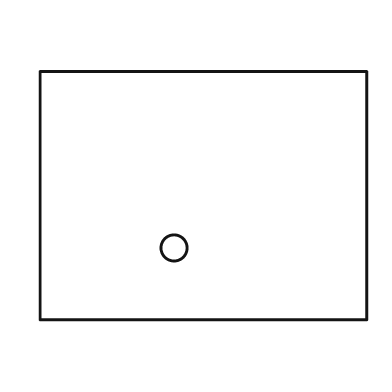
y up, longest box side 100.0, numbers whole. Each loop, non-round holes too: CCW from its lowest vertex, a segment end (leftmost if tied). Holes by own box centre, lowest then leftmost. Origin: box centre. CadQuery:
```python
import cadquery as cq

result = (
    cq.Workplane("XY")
    .moveTo(-50.0, -38.0)
    .lineTo(50.0, -38.0)
    .lineTo(50.0, 38.0)
    .lineTo(-50.0, 38.0)
    .close()
    .moveTo(-9.0, -16.0)
    .circle(4.0)
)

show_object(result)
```